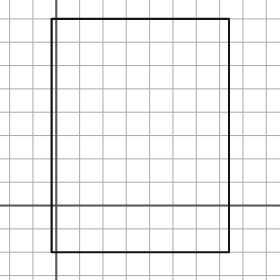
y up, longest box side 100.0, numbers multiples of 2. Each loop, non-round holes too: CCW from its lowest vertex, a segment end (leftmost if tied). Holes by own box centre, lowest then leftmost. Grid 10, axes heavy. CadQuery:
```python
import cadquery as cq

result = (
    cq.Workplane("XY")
    .moveTo(-2.0, -20.0)
    .lineTo(74.0, -20.0)
    .lineTo(74.0, 80.0)
    .lineTo(-2.0, 80.0)
    .close()
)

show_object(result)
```